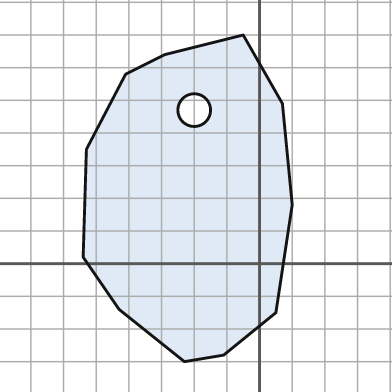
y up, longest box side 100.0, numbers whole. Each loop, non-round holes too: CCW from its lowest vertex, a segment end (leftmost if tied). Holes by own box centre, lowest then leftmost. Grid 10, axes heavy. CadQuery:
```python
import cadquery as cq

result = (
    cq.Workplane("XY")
    .moveTo(-23.0, -30.0)
    .lineTo(-11.0, -28.0)
    .lineTo(5.0, -15.0)
    .lineTo(10.0, 18.0)
    .lineTo(7.0, 49.0)
    .lineTo(-5.0, 70.0)
    .lineTo(-29.0, 64.0)
    .lineTo(-41.0, 58.0)
    .lineTo(-53.0, 35.0)
    .lineTo(-54.0, 2.0)
    .lineTo(-43.0, -14.0)
    .close()
    .moveTo(-20.0, 47.0)
    .circle(5.0)
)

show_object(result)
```